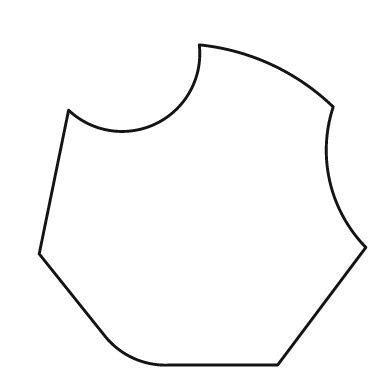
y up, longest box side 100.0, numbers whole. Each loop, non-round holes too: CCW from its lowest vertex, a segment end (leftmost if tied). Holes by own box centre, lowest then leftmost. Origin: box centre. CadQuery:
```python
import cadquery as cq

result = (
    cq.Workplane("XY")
    .moveTo(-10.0, -49.0)
    .lineTo(23.0, -49.0)
    .lineTo(50.0, -13.0)
    .threePointArc((39.0, 7.0), (40.0, 30.0))
    .threePointArc((21.0, 43.0), (-1.0, 49.0))
    .threePointArc((-14.0, 25.0), (-41.0, 29.0))
    .lineTo(-50.0, -15.0)
    .lineTo(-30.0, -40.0)
    .threePointArc((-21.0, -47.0), (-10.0, -49.0))
    .close()
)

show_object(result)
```